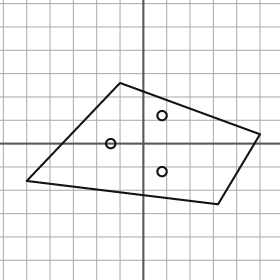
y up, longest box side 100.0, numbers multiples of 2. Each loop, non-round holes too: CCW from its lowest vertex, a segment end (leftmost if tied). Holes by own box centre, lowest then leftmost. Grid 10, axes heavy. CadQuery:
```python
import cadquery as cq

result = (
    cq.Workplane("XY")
    .moveTo(32.0, -26.0)
    .lineTo(50.0, 4.0)
    .lineTo(-10.0, 26.0)
    .lineTo(-50.0, -16.0)
    .close()
    .moveTo(8.0, -12.0)
    .circle(2.0)
    .moveTo(-14.0, 0.0)
    .circle(2.0)
    .moveTo(8.0, 12.0)
    .circle(2.0)
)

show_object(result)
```